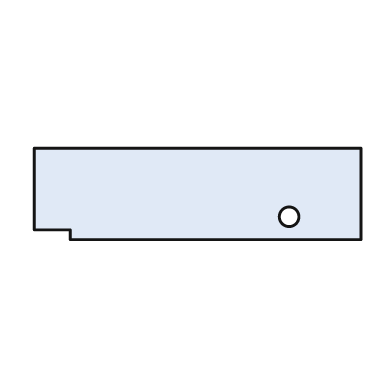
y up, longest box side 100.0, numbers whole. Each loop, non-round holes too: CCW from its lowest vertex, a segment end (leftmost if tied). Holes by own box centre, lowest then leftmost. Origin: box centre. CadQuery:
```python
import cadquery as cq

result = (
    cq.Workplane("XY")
    .moveTo(-39.0, -14.0)
    .lineTo(50.0, -14.0)
    .lineTo(50.0, 14.0)
    .lineTo(-50.0, 14.0)
    .lineTo(-50.0, -11.0)
    .lineTo(-39.0, -11.0)
    .close()
    .moveTo(28.0, -7.0)
    .circle(3.0)
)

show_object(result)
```